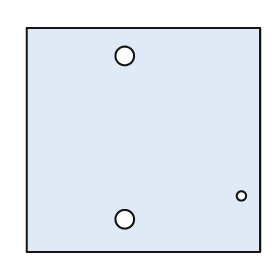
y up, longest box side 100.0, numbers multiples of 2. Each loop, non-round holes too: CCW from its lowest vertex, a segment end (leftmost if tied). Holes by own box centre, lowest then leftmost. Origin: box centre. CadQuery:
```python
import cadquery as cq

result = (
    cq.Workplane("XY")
    .moveTo(-50.0, -48.0)
    .lineTo(50.0, -48.0)
    .lineTo(50.0, 48.0)
    .lineTo(-50.0, 48.0)
    .close()
    .moveTo(-8.0, -34.0)
    .circle(4.0)
    .moveTo(42.0, -24.0)
    .circle(2.0)
    .moveTo(-8.0, 36.0)
    .circle(4.0)
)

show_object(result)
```